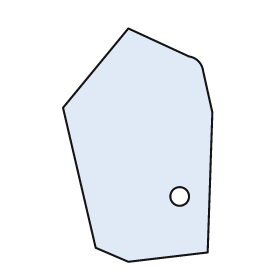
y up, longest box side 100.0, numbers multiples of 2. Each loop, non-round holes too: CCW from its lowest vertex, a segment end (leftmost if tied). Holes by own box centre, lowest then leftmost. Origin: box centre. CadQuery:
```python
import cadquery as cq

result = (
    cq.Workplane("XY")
    .moveTo(-4.0, -50.0)
    .lineTo(30.0, -46.0)
    .lineTo(32.0, 14.0)
    .lineTo(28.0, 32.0)
    .threePointArc((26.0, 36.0), (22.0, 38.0))
    .lineTo(-4.0, 50.0)
    .lineTo(-32.0, 16.0)
    .lineTo(-18.0, -44.0)
    .close()
    .moveTo(18.0, -22.0)
    .circle(4.0)
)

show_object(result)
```